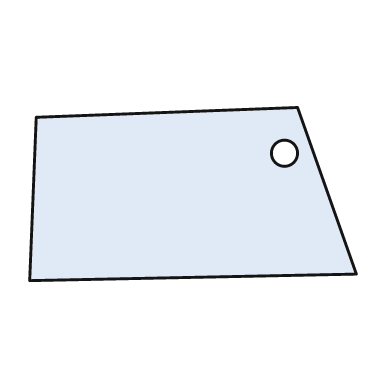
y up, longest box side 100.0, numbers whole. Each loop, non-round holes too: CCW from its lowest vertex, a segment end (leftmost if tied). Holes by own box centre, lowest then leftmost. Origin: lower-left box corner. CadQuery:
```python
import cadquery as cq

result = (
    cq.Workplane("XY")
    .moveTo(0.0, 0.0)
    .lineTo(100.0, 2.0)
    .lineTo(82.0, 53.0)
    .lineTo(2.0, 50.0)
    .close()
    .moveTo(78.0, 39.0)
    .circle(4.0)
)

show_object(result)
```